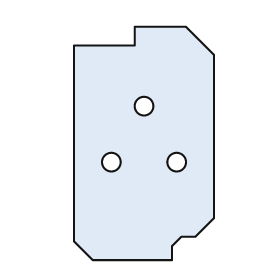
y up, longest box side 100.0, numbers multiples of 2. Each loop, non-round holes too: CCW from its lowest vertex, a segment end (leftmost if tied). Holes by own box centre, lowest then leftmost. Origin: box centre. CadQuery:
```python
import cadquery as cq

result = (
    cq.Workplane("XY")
    .moveTo(-22.0, -50.0)
    .lineTo(12.0, -50.0)
    .lineTo(12.0, -44.0)
    .lineTo(16.0, -40.0)
    .lineTo(22.0, -40.0)
    .lineTo(30.0, -32.0)
    .lineTo(30.0, 38.0)
    .lineTo(18.0, 50.0)
    .lineTo(-4.0, 50.0)
    .lineTo(-4.0, 42.0)
    .lineTo(-30.0, 42.0)
    .lineTo(-30.0, -42.0)
    .close()
    .moveTo(-14.0, -8.0)
    .circle(4.0)
    .moveTo(14.0, -8.0)
    .circle(4.0)
    .moveTo(0.0, 16.0)
    .circle(4.0)
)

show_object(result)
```